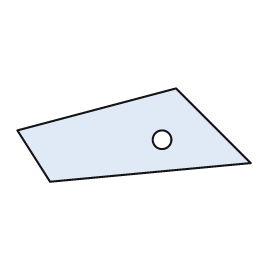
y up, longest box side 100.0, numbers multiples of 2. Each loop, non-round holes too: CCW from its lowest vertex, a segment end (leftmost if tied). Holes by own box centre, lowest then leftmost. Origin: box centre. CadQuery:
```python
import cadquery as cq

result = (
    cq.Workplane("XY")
    .moveTo(-36.0, -20.0)
    .lineTo(50.0, -12.0)
    .lineTo(18.0, 20.0)
    .lineTo(-50.0, 2.0)
    .close()
    .moveTo(12.0, -2.0)
    .circle(4.0)
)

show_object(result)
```